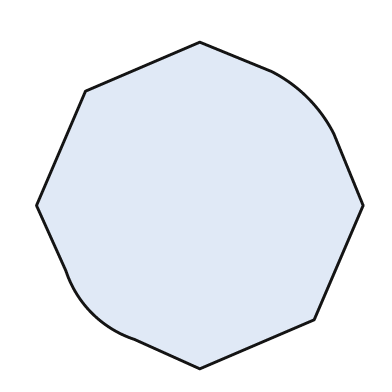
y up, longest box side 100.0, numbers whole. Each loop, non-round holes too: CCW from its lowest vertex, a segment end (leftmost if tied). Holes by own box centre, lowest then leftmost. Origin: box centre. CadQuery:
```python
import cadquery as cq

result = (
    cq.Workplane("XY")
    .moveTo(0.0, -50.0)
    .lineTo(35.0, -35.0)
    .lineTo(50.0, 0.0)
    .lineTo(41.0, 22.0)
    .threePointArc((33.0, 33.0), (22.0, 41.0))
    .lineTo(0.0, 50.0)
    .lineTo(-35.0, 35.0)
    .lineTo(-50.0, 0.0)
    .lineTo(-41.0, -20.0)
    .threePointArc((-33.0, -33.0), (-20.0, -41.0))
    .close()
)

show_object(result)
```